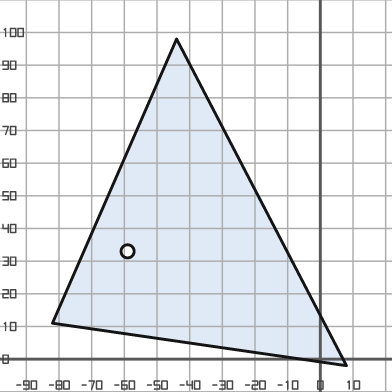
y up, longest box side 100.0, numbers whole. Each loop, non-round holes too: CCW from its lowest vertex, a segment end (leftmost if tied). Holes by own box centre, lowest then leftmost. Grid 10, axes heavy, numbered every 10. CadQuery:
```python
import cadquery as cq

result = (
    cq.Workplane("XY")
    .moveTo(8.0, -2.0)
    .lineTo(-44.0, 98.0)
    .lineTo(-82.0, 11.0)
    .close()
    .moveTo(-59.0, 33.0)
    .circle(2.0)
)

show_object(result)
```